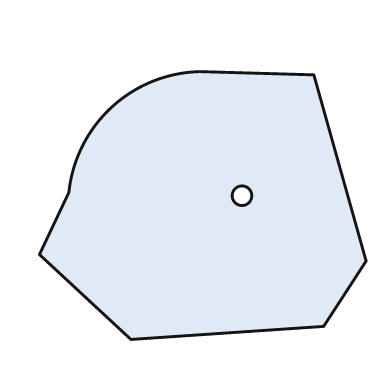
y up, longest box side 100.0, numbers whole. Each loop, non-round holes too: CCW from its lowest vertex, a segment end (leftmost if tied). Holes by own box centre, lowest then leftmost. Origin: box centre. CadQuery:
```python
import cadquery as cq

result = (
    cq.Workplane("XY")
    .moveTo(-22.0, -41.0)
    .lineTo(37.0, -37.0)
    .lineTo(50.0, -17.0)
    .lineTo(34.0, 40.0)
    .lineTo(-1.0, 41.0)
    .threePointArc((-28.0, 30.0), (-41.0, 4.0))
    .lineTo(-50.0, -15.0)
    .close()
    .moveTo(12.0, 3.0)
    .circle(3.0)
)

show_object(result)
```